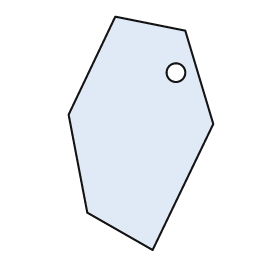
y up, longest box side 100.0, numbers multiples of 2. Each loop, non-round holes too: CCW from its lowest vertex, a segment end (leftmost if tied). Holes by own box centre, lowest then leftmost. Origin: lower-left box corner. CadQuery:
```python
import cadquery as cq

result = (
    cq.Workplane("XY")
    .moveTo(36.0, 0.0)
    .lineTo(62.0, 54.0)
    .lineTo(50.0, 94.0)
    .lineTo(20.0, 100.0)
    .lineTo(0.0, 58.0)
    .lineTo(8.0, 16.0)
    .close()
    .moveTo(46.0, 76.0)
    .circle(4.0)
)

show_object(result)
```